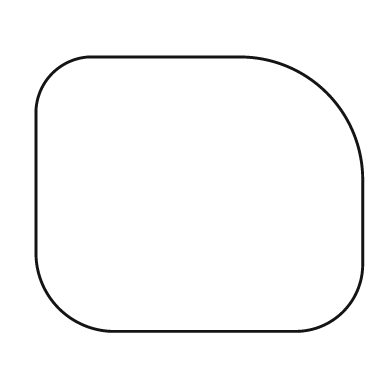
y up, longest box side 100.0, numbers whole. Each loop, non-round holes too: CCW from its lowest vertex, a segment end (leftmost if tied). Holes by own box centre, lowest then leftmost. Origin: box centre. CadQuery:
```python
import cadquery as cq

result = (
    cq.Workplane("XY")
    .moveTo(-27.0, -42.0)
    .lineTo(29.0, -42.0)
    .threePointArc((44.0, -36.0), (50.0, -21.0))
    .lineTo(50.0, 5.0)
    .threePointArc((39.0, 31.0), (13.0, 42.0))
    .lineTo(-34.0, 42.0)
    .threePointArc((-45.0, 37.0), (-50.0, 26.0))
    .lineTo(-50.0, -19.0)
    .threePointArc((-43.0, -35.0), (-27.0, -42.0))
    .close()
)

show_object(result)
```